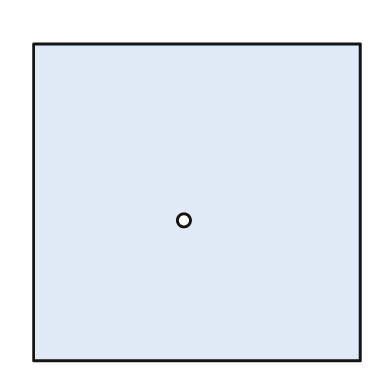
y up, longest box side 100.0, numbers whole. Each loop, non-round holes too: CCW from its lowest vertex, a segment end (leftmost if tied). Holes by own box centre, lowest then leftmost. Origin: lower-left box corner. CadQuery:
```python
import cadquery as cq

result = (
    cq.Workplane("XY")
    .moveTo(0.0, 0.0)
    .lineTo(100.0, 0.0)
    .lineTo(100.0, 97.0)
    .lineTo(0.0, 97.0)
    .close()
    .moveTo(46.0, 43.0)
    .circle(2.0)
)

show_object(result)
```